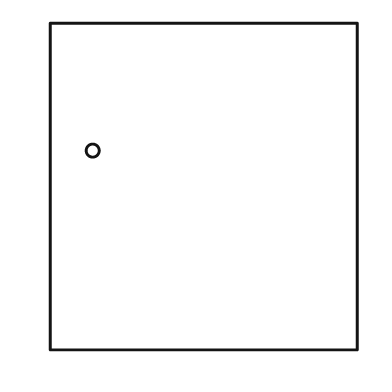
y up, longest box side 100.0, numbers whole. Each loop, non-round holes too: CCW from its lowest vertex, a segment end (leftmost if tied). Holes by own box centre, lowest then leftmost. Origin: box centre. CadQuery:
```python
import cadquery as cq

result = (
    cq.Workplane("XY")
    .moveTo(-47.0, -50.0)
    .lineTo(47.0, -50.0)
    .lineTo(47.0, 50.0)
    .lineTo(-47.0, 50.0)
    .close()
    .moveTo(-34.0, 11.0)
    .circle(2.0)
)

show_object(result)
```